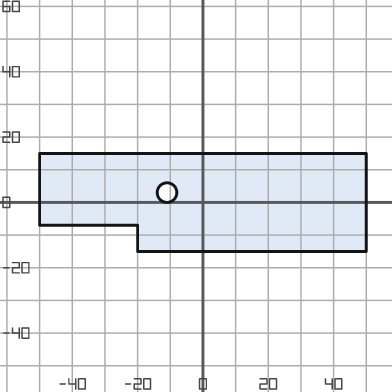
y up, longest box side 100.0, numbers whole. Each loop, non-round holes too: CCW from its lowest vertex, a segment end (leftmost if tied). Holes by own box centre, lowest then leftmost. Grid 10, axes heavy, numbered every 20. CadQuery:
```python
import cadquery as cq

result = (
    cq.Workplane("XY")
    .moveTo(-20.0, -15.0)
    .lineTo(50.0, -15.0)
    .lineTo(50.0, 15.0)
    .lineTo(-50.0, 15.0)
    .lineTo(-50.0, -7.0)
    .lineTo(-20.0, -7.0)
    .close()
    .moveTo(-11.0, 3.0)
    .circle(3.0)
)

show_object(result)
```